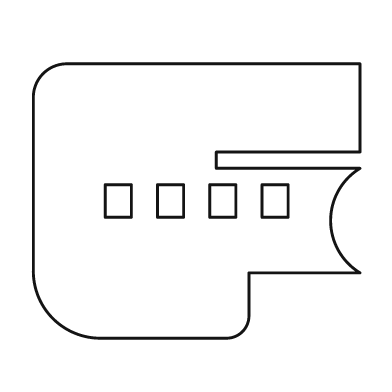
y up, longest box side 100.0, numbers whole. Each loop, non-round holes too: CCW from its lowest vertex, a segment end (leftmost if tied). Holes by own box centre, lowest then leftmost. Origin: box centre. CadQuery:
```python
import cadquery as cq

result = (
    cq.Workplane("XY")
    .moveTo(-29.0, -42.0)
    .lineTo(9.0, -42.0)
    .threePointArc((14.0, -40.0), (16.0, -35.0))
    .lineTo(16.0, -22.0)
    .lineTo(50.0, -22.0)
    .threePointArc((41.0, -6.0), (50.0, 10.0))
    .lineTo(6.0, 10.0)
    .lineTo(6.0, 15.0)
    .lineTo(50.0, 15.0)
    .lineTo(50.0, 42.0)
    .lineTo(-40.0, 42.0)
    .threePointArc((-47.0, 39.0), (-50.0, 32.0))
    .lineTo(-50.0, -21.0)
    .threePointArc((-44.0, -36.0), (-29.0, -42.0))
    .close()
    .moveTo(-28.0, -5.0)
    .lineTo(-20.0, -5.0)
    .lineTo(-20.0, 5.0)
    .lineTo(-28.0, 5.0)
    .close()
    .moveTo(-12.0, -5.0)
    .lineTo(-4.0, -5.0)
    .lineTo(-4.0, 5.0)
    .lineTo(-12.0, 5.0)
    .close()
    .moveTo(4.0, -5.0)
    .lineTo(12.0, -5.0)
    .lineTo(12.0, 5.0)
    .lineTo(4.0, 5.0)
    .close()
    .moveTo(20.0, -5.0)
    .lineTo(28.0, -5.0)
    .lineTo(28.0, 5.0)
    .lineTo(20.0, 5.0)
    .close()
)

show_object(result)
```